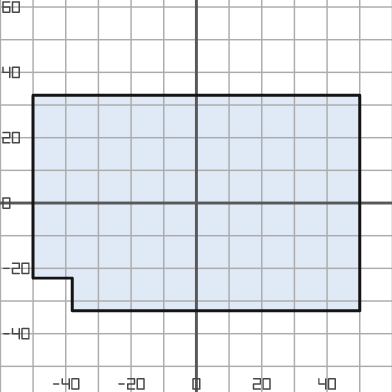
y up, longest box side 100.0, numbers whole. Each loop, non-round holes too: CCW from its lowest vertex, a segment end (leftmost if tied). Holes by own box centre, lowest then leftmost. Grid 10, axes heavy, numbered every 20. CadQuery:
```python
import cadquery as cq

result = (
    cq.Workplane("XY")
    .moveTo(-38.0, -33.0)
    .lineTo(50.0, -33.0)
    .lineTo(50.0, 33.0)
    .lineTo(-50.0, 33.0)
    .lineTo(-50.0, -23.0)
    .lineTo(-38.0, -23.0)
    .close()
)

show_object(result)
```